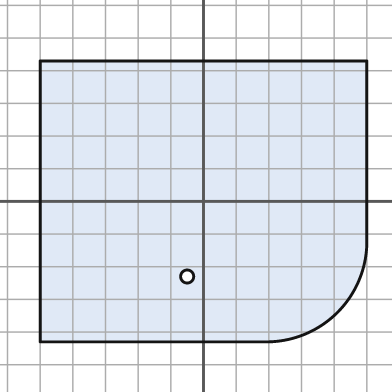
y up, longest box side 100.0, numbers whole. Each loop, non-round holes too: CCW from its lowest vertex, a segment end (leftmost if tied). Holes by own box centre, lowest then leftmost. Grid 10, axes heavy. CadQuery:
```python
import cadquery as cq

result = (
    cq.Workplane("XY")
    .moveTo(-50.0, -43.0)
    .lineTo(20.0, -43.0)
    .threePointArc((41.0, -34.0), (50.0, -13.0))
    .lineTo(50.0, 43.0)
    .lineTo(-50.0, 43.0)
    .close()
    .moveTo(-5.0, -23.0)
    .circle(2.0)
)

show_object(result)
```